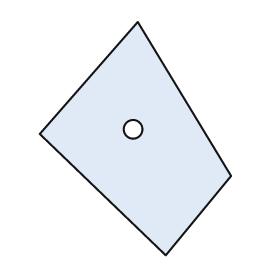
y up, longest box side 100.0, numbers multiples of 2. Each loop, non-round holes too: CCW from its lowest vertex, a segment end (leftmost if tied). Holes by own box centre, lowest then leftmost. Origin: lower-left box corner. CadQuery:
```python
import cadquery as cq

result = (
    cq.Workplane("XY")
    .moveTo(54.0, 0.0)
    .lineTo(82.0, 34.0)
    .lineTo(42.0, 100.0)
    .lineTo(0.0, 52.0)
    .close()
    .moveTo(40.0, 54.0)
    .circle(4.0)
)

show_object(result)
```